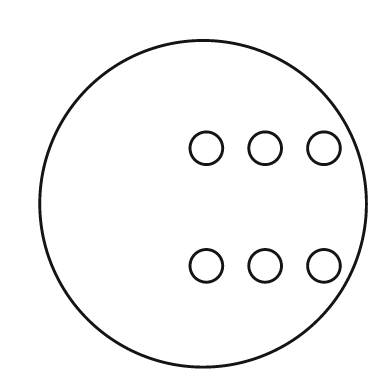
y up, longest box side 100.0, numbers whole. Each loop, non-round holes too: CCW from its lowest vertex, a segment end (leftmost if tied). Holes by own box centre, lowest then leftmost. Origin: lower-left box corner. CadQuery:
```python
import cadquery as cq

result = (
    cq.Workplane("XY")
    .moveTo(50.0, 50.0)
    .circle(50.0)
    .moveTo(51.0, 31.0)
    .circle(5.0)
    .moveTo(69.0, 31.0)
    .circle(5.0)
    .moveTo(87.0, 31.0)
    .circle(5.0)
    .moveTo(51.0, 67.0)
    .circle(5.0)
    .moveTo(69.0, 67.0)
    .circle(5.0)
    .moveTo(87.0, 67.0)
    .circle(5.0)
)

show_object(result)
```